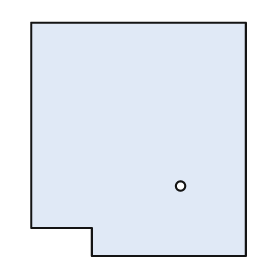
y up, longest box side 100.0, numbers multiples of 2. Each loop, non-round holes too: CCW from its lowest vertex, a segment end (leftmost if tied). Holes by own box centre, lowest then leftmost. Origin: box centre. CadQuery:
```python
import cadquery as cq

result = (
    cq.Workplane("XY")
    .moveTo(-20.0, -50.0)
    .lineTo(46.0, -50.0)
    .lineTo(46.0, 50.0)
    .lineTo(-46.0, 50.0)
    .lineTo(-46.0, -38.0)
    .lineTo(-20.0, -38.0)
    .close()
    .moveTo(18.0, -20.0)
    .circle(2.0)
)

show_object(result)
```